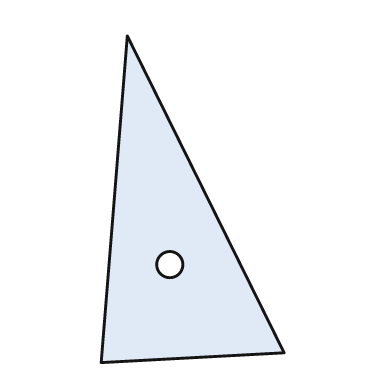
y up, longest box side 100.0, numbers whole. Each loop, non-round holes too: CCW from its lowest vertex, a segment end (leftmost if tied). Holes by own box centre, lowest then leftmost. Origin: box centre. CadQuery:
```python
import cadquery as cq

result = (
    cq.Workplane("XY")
    .moveTo(-28.0, -50.0)
    .lineTo(28.0, -47.0)
    .lineTo(-20.0, 50.0)
    .close()
    .moveTo(-7.0, -20.0)
    .circle(4.0)
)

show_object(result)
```